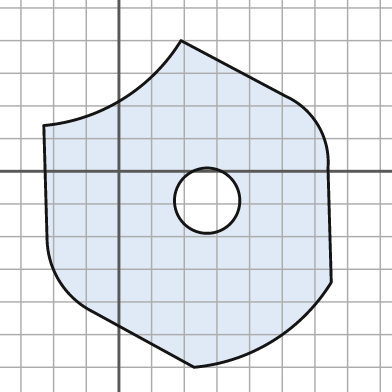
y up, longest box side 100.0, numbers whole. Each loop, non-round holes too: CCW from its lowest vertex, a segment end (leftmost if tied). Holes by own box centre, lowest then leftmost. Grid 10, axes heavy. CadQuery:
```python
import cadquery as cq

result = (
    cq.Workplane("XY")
    .moveTo(23.0, -60.0)
    .threePointArc((47.0, -52.0), (65.0, -34.0))
    .lineTo(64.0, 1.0)
    .threePointArc((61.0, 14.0), (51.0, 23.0))
    .lineTo(19.0, 40.0)
    .threePointArc((1.0, 22.0), (-23.0, 14.0))
    .lineTo(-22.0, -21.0)
    .threePointArc((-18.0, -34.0), (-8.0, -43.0))
    .close()
    .moveTo(27.0, -9.0)
    .circle(10.0)
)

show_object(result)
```